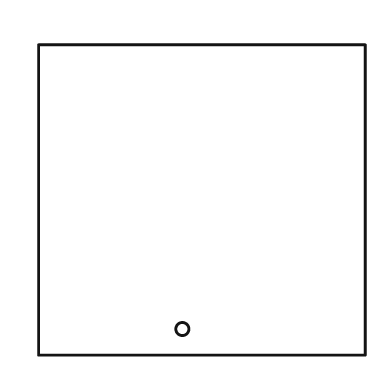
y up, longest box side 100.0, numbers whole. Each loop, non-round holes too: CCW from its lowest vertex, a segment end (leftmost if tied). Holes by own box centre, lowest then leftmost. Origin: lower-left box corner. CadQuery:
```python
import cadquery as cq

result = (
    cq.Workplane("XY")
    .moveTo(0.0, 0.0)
    .lineTo(100.0, 0.0)
    .lineTo(100.0, 95.0)
    .lineTo(0.0, 95.0)
    .close()
    .moveTo(44.0, 8.0)
    .circle(2.0)
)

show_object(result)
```